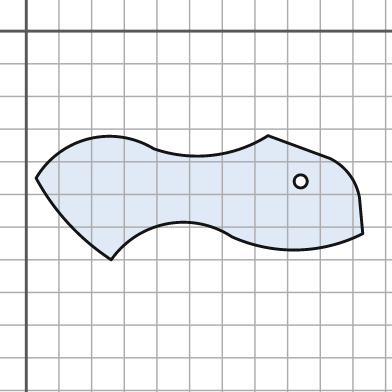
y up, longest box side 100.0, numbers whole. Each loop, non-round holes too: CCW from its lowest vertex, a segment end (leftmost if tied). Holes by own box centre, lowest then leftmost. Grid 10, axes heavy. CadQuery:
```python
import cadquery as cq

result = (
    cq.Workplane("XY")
    .moveTo(26.0, -70.0)
    .threePointArc((43.0, -59.0), (63.0, -63.0))
    .threePointArc((83.0, -67.0), (103.0, -62.0))
    .lineTo(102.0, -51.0)
    .threePointArc((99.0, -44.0), (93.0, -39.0))
    .lineTo(74.0, -32.0)
    .threePointArc((57.0, -38.0), (39.0, -36.0))
    .threePointArc((19.0, -33.0), (3.0, -45.0))
    .threePointArc((13.0, -59.0), (26.0, -70.0))
    .close()
    .moveTo(84.0, -46.0)
    .circle(2.0)
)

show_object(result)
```